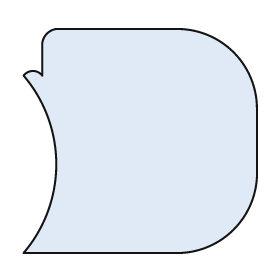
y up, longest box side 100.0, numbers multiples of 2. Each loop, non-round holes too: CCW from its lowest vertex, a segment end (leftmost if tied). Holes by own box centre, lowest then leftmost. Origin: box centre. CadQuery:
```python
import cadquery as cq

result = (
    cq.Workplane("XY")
    .moveTo(-50.0, -48.0)
    .lineTo(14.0, -48.0)
    .threePointArc((40.0, -38.0), (50.0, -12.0))
    .lineTo(50.0, 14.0)
    .threePointArc((40.0, 38.0), (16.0, 48.0))
    .lineTo(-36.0, 48.0)
    .threePointArc((-40.0, 46.0), (-42.0, 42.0))
    .lineTo(-42.0, 28.0)
    .threePointArc((-46.0, 30.0), (-50.0, 28.0))
    .threePointArc((-36.0, -10.0), (-50.0, -48.0))
    .close()
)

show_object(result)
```